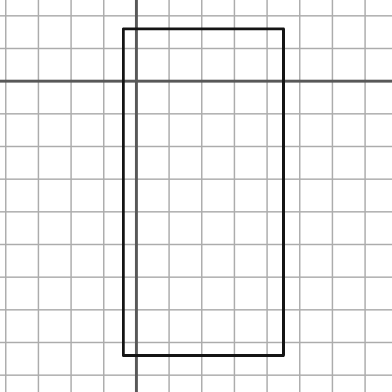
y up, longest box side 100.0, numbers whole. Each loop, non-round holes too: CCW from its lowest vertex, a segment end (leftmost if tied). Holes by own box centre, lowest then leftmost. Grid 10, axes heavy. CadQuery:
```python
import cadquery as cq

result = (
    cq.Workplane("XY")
    .moveTo(-4.0, -84.0)
    .lineTo(45.0, -84.0)
    .lineTo(45.0, 16.0)
    .lineTo(-4.0, 16.0)
    .close()
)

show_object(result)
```